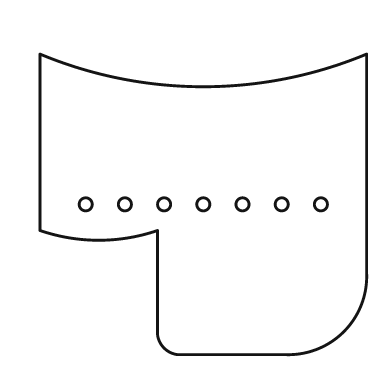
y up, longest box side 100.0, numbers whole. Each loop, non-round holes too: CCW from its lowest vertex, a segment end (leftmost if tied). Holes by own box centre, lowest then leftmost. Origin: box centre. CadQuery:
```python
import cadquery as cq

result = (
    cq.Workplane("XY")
    .moveTo(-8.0, -46.0)
    .lineTo(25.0, -46.0)
    .threePointArc((43.0, -39.0), (50.0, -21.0))
    .lineTo(50.0, 46.0)
    .threePointArc((0.0, 36.0), (-50.0, 46.0))
    .lineTo(-50.0, -8.0)
    .threePointArc((-32.0, -11.0), (-14.0, -8.0))
    .lineTo(-14.0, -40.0)
    .threePointArc((-12.0, -44.0), (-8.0, -46.0))
    .close()
    .moveTo(-36.0, 0.0)
    .circle(2.0)
    .moveTo(-24.0, 0.0)
    .circle(2.0)
    .moveTo(-12.0, 0.0)
    .circle(2.0)
    .moveTo(0.0, 0.0)
    .circle(2.0)
    .moveTo(12.0, 0.0)
    .circle(2.0)
    .moveTo(24.0, 0.0)
    .circle(2.0)
    .moveTo(36.0, 0.0)
    .circle(2.0)
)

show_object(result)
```